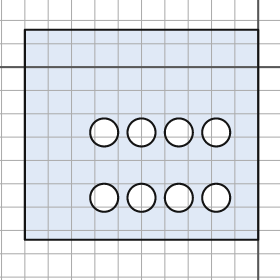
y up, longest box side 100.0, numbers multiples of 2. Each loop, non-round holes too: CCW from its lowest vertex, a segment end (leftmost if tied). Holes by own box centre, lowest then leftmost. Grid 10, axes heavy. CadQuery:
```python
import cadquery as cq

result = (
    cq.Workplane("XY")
    .moveTo(-100.0, -74.0)
    .lineTo(0.0, -74.0)
    .lineTo(0.0, 16.0)
    .lineTo(-100.0, 16.0)
    .close()
    .moveTo(-66.0, -56.0)
    .circle(6.0)
    .moveTo(-50.0, -56.0)
    .circle(6.0)
    .moveTo(-34.0, -56.0)
    .circle(6.0)
    .moveTo(-18.0, -56.0)
    .circle(6.0)
    .moveTo(-66.0, -28.0)
    .circle(6.0)
    .moveTo(-50.0, -28.0)
    .circle(6.0)
    .moveTo(-34.0, -28.0)
    .circle(6.0)
    .moveTo(-18.0, -28.0)
    .circle(6.0)
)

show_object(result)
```